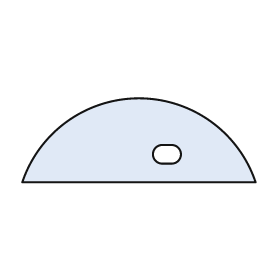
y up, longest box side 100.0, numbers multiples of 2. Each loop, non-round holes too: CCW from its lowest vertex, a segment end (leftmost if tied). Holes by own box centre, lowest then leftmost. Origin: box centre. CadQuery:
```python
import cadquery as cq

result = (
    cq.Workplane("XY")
    .moveTo(-50.0, -18.0)
    .lineTo(50.0, -18.0)
    .threePointArc((0.0, 18.0), (-50.0, -18.0))
    .close()
    .moveTo(10.0, -10.0)
    .lineTo(14.0, -10.0)
    .threePointArc((18.0, -6.0), (14.0, -2.0))
    .lineTo(10.0, -2.0)
    .threePointArc((6.0, -6.0), (10.0, -10.0))
    .close()
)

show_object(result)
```